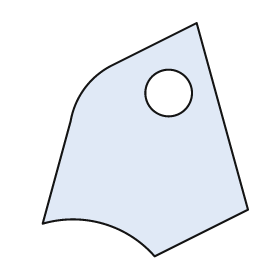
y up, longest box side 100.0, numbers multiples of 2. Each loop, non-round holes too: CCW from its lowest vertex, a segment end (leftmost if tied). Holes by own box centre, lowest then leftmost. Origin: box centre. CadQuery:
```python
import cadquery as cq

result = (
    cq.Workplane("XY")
    .moveTo(4.0, -50.0)
    .lineTo(44.0, -30.0)
    .lineTo(22.0, 50.0)
    .lineTo(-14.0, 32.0)
    .threePointArc((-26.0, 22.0), (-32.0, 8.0))
    .lineTo(-44.0, -36.0)
    .threePointArc((-18.0, -36.0), (4.0, -50.0))
    .close()
    .moveTo(10.0, 20.0)
    .circle(10.0)
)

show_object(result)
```